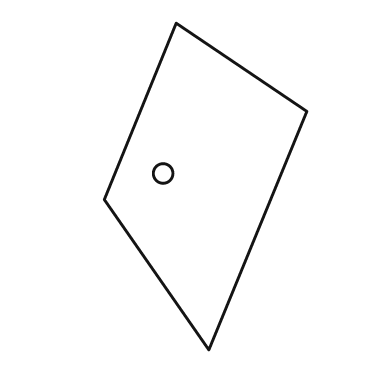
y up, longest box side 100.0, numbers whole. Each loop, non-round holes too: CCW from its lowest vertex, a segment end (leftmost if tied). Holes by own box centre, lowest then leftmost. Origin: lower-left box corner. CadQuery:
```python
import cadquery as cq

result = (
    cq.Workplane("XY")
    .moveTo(32.0, 0.0)
    .lineTo(62.0, 73.0)
    .lineTo(22.0, 100.0)
    .lineTo(0.0, 46.0)
    .close()
    .moveTo(18.0, 54.0)
    .circle(3.0)
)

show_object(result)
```